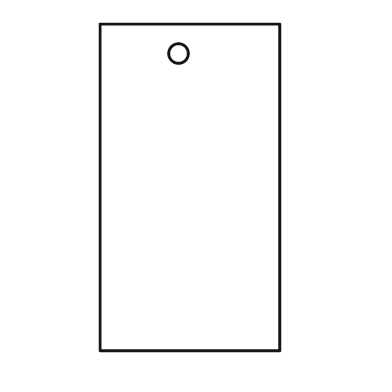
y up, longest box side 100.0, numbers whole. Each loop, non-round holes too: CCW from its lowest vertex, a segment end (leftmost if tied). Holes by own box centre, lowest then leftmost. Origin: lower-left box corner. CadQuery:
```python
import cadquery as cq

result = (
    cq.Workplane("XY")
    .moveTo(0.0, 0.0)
    .lineTo(55.0, 0.0)
    .lineTo(55.0, 100.0)
    .lineTo(0.0, 100.0)
    .close()
    .moveTo(24.0, 91.0)
    .circle(3.0)
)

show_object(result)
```